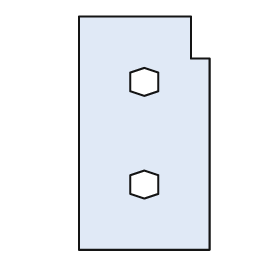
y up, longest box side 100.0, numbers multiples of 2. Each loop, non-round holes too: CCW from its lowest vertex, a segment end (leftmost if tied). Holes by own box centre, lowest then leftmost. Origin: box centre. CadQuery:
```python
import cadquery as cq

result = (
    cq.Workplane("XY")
    .moveTo(-28.0, -50.0)
    .lineTo(28.0, -50.0)
    .lineTo(28.0, 32.0)
    .lineTo(20.0, 32.0)
    .lineTo(20.0, 50.0)
    .lineTo(-28.0, 50.0)
    .close()
    .moveTo(0.0, -28.0)
    .lineTo(6.0, -26.0)
    .lineTo(6.0, -18.0)
    .lineTo(0.0, -16.0)
    .lineTo(-6.0, -18.0)
    .lineTo(-6.0, -26.0)
    .close()
    .moveTo(0.0, 16.0)
    .lineTo(6.0, 18.0)
    .lineTo(6.0, 26.0)
    .lineTo(0.0, 28.0)
    .lineTo(-6.0, 26.0)
    .lineTo(-6.0, 18.0)
    .close()
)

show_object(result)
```